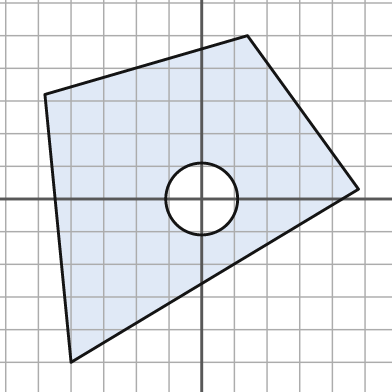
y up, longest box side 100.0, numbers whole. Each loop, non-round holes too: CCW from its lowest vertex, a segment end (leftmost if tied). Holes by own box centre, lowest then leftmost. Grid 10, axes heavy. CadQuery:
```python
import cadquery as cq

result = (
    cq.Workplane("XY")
    .moveTo(-40.0, -50.0)
    .lineTo(48.0, 3.0)
    .lineTo(14.0, 50.0)
    .lineTo(-48.0, 32.0)
    .close()
    .moveTo(0.0, 0.0)
    .circle(11.0)
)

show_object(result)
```